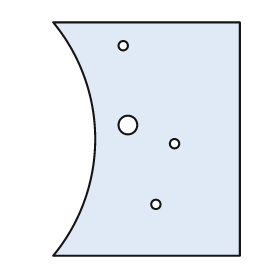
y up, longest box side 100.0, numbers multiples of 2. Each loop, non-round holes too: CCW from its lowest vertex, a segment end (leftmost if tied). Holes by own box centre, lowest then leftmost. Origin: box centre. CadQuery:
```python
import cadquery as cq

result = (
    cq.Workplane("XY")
    .moveTo(-40.0, -50.0)
    .lineTo(40.0, -50.0)
    .lineTo(40.0, 50.0)
    .lineTo(-40.0, 50.0)
    .threePointArc((-22.0, 0.0), (-40.0, -50.0))
    .close()
    .moveTo(4.0, -28.0)
    .circle(2.0)
    .moveTo(12.0, -2.0)
    .circle(2.0)
    .moveTo(-8.0, 6.0)
    .circle(4.0)
    .moveTo(-10.0, 40.0)
    .circle(2.0)
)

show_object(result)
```